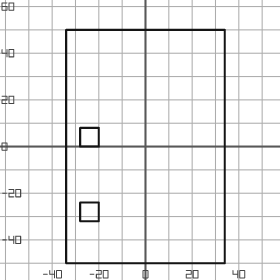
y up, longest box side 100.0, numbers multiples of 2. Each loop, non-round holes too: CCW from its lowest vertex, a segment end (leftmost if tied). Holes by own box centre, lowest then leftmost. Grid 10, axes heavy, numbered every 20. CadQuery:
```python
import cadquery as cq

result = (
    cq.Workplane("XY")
    .moveTo(-34.0, -50.0)
    .lineTo(34.0, -50.0)
    .lineTo(34.0, 50.0)
    .lineTo(-34.0, 50.0)
    .close()
    .moveTo(-28.0, -32.0)
    .lineTo(-20.0, -32.0)
    .lineTo(-20.0, -24.0)
    .lineTo(-28.0, -24.0)
    .close()
    .moveTo(-28.0, 0.0)
    .lineTo(-20.0, 0.0)
    .lineTo(-20.0, 8.0)
    .lineTo(-28.0, 8.0)
    .close()
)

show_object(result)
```